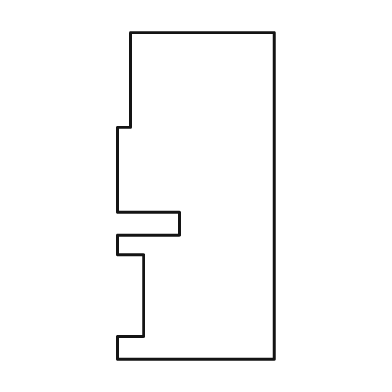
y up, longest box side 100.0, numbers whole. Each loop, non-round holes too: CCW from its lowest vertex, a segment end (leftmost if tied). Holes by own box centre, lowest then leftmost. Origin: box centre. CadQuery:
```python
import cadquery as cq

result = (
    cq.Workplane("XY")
    .moveTo(-24.0, -50.0)
    .lineTo(24.0, -50.0)
    .lineTo(24.0, 50.0)
    .lineTo(-20.0, 50.0)
    .lineTo(-20.0, 21.0)
    .lineTo(-24.0, 21.0)
    .lineTo(-24.0, -5.0)
    .lineTo(-5.0, -5.0)
    .lineTo(-5.0, -12.0)
    .lineTo(-24.0, -12.0)
    .lineTo(-24.0, -18.0)
    .lineTo(-16.0, -18.0)
    .lineTo(-16.0, -43.0)
    .lineTo(-24.0, -43.0)
    .close()
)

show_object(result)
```